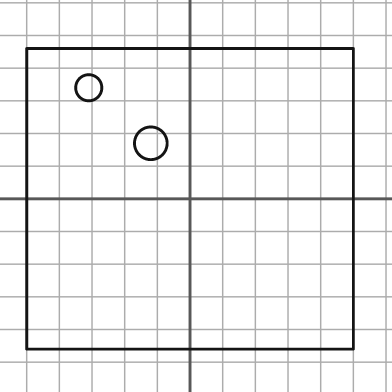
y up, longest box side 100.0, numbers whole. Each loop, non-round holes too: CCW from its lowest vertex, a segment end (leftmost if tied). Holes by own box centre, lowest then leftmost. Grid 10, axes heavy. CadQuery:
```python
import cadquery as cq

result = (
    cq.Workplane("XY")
    .moveTo(-50.0, -46.0)
    .lineTo(50.0, -46.0)
    .lineTo(50.0, 46.0)
    .lineTo(-50.0, 46.0)
    .close()
    .moveTo(-12.0, 17.0)
    .circle(5.0)
    .moveTo(-31.0, 34.0)
    .circle(4.0)
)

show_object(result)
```